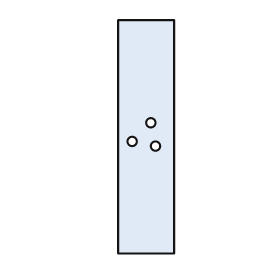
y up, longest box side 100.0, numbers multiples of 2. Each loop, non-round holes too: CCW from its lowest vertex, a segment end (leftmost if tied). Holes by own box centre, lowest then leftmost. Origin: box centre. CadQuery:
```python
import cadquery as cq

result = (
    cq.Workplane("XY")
    .moveTo(-12.0, -50.0)
    .lineTo(12.0, -50.0)
    .lineTo(12.0, 50.0)
    .lineTo(-12.0, 50.0)
    .close()
    .moveTo(4.0, -4.0)
    .circle(2.0)
    .moveTo(-6.0, -2.0)
    .circle(2.0)
    .moveTo(2.0, 6.0)
    .circle(2.0)
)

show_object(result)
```